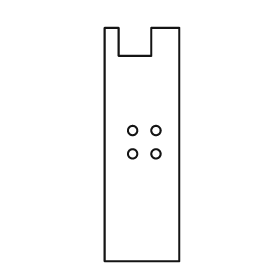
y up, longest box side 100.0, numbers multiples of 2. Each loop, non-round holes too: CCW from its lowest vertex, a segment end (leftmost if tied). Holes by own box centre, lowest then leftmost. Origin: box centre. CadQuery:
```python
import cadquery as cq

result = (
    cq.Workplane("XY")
    .moveTo(-16.0, -50.0)
    .lineTo(16.0, -50.0)
    .lineTo(16.0, 50.0)
    .lineTo(4.0, 50.0)
    .lineTo(4.0, 38.0)
    .lineTo(-10.0, 38.0)
    .lineTo(-10.0, 50.0)
    .lineTo(-16.0, 50.0)
    .close()
    .moveTo(-4.0, -4.0)
    .circle(2.0)
    .moveTo(6.0, -4.0)
    .circle(2.0)
    .moveTo(-4.0, 6.0)
    .circle(2.0)
    .moveTo(6.0, 6.0)
    .circle(2.0)
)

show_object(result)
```